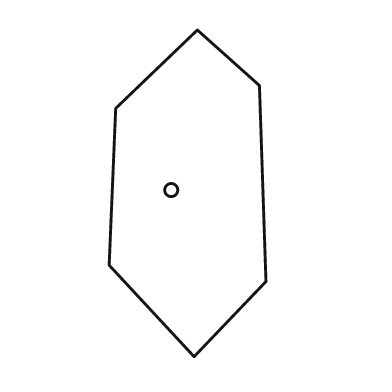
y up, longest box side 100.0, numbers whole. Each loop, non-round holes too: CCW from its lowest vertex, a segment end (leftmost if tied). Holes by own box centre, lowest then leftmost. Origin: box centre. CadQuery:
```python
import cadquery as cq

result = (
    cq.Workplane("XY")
    .moveTo(2.0, -50.0)
    .lineTo(24.0, -27.0)
    .lineTo(22.0, 33.0)
    .lineTo(3.0, 50.0)
    .lineTo(-22.0, 26.0)
    .lineTo(-24.0, -22.0)
    .close()
    .moveTo(-5.0, 1.0)
    .circle(2.0)
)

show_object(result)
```